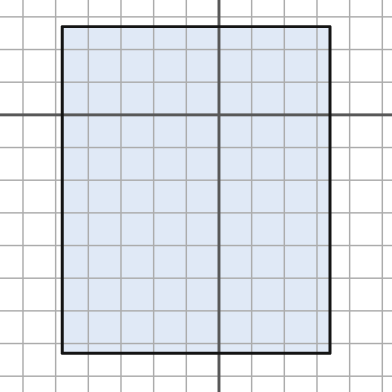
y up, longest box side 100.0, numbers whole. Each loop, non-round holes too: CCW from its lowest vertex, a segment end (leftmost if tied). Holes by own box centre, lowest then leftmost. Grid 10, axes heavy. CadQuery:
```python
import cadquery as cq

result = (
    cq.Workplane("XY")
    .moveTo(-48.0, -73.0)
    .lineTo(34.0, -73.0)
    .lineTo(34.0, 27.0)
    .lineTo(-48.0, 27.0)
    .close()
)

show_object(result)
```